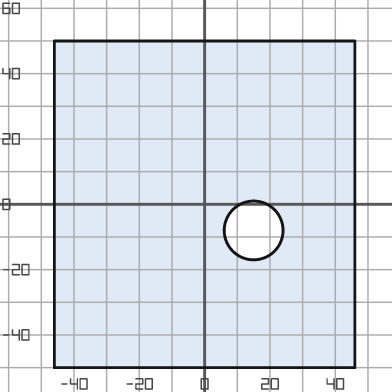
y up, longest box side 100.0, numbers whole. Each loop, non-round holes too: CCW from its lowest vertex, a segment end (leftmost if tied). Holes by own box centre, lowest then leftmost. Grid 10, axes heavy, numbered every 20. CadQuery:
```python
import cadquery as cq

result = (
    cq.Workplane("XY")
    .moveTo(-46.0, -50.0)
    .lineTo(46.0, -50.0)
    .lineTo(46.0, 50.0)
    .lineTo(-46.0, 50.0)
    .close()
    .moveTo(15.0, -8.0)
    .circle(9.0)
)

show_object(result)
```